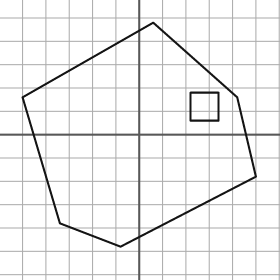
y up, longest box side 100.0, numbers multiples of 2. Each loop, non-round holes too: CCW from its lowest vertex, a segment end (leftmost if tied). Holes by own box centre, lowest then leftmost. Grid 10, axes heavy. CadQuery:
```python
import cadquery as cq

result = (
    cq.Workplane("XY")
    .moveTo(-8.0, -48.0)
    .lineTo(50.0, -18.0)
    .lineTo(42.0, 16.0)
    .lineTo(6.0, 48.0)
    .lineTo(-50.0, 16.0)
    .lineTo(-34.0, -38.0)
    .close()
    .moveTo(22.0, 6.0)
    .lineTo(34.0, 6.0)
    .lineTo(34.0, 18.0)
    .lineTo(22.0, 18.0)
    .close()
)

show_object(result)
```